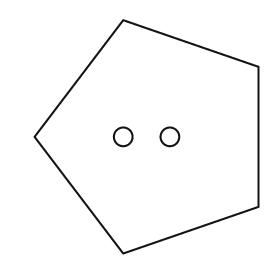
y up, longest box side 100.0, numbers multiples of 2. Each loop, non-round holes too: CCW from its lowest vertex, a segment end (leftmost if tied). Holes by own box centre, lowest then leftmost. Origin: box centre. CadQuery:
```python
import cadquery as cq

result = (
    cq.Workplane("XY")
    .moveTo(-10.0, -50.0)
    .lineTo(48.0, -30.0)
    .lineTo(48.0, 30.0)
    .lineTo(-10.0, 50.0)
    .lineTo(-48.0, 0.0)
    .close()
    .moveTo(-10.0, 0.0)
    .circle(4.0)
    .moveTo(10.0, 0.0)
    .circle(4.0)
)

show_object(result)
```